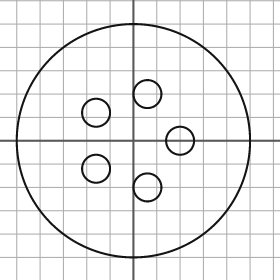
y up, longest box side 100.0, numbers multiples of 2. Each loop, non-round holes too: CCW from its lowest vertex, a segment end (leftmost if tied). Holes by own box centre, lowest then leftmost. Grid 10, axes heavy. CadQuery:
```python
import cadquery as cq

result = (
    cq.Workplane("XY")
    .moveTo(0.0, 0.0)
    .circle(50.0)
    .moveTo(6.0, -20.0)
    .circle(6.0)
    .moveTo(-16.0, -12.0)
    .circle(6.0)
    .moveTo(20.0, 0.0)
    .circle(6.0)
    .moveTo(-16.0, 12.0)
    .circle(6.0)
    .moveTo(6.0, 20.0)
    .circle(6.0)
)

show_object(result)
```